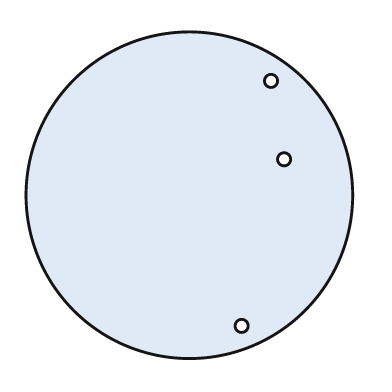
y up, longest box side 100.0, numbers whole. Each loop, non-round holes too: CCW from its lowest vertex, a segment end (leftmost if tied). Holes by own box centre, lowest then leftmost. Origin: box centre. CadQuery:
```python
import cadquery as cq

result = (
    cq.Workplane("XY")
    .moveTo(0.0, 0.0)
    .circle(50.0)
    .moveTo(16.0, -40.0)
    .circle(2.0)
    .moveTo(29.0, 11.0)
    .circle(2.0)
    .moveTo(25.0, 35.0)
    .circle(2.0)
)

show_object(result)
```